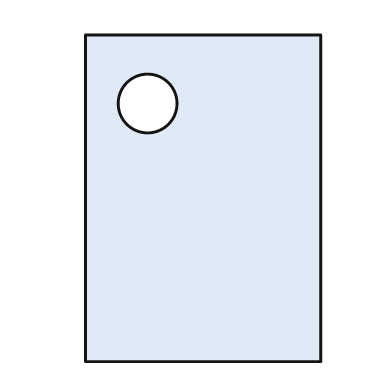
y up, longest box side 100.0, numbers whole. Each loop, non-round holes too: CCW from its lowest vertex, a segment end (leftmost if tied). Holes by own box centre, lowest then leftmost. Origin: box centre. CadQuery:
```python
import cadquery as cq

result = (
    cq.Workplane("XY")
    .moveTo(-36.0, -50.0)
    .lineTo(36.0, -50.0)
    .lineTo(36.0, 50.0)
    .lineTo(-36.0, 50.0)
    .close()
    .moveTo(-17.0, 29.0)
    .circle(9.0)
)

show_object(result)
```